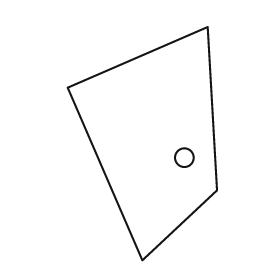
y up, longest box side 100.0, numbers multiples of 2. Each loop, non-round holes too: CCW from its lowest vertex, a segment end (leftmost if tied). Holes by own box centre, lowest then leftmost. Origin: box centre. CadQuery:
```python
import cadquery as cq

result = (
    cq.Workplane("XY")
    .moveTo(0.0, -50.0)
    .lineTo(32.0, -20.0)
    .lineTo(28.0, 50.0)
    .lineTo(-32.0, 24.0)
    .close()
    .moveTo(18.0, -6.0)
    .circle(4.0)
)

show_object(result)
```